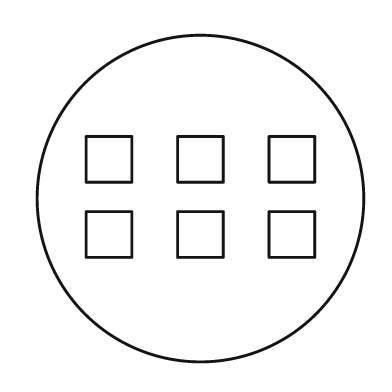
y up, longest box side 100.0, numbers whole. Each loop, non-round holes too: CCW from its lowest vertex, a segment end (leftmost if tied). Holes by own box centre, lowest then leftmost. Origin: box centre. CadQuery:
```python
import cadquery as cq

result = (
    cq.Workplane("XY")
    .moveTo(0.0, 0.0)
    .circle(50.0)
    .moveTo(-35.0, -18.0)
    .lineTo(-21.0, -18.0)
    .lineTo(-21.0, -4.0)
    .lineTo(-35.0, -4.0)
    .close()
    .moveTo(-7.0, -18.0)
    .lineTo(7.0, -18.0)
    .lineTo(7.0, -4.0)
    .lineTo(-7.0, -4.0)
    .close()
    .moveTo(21.0, -18.0)
    .lineTo(35.0, -18.0)
    .lineTo(35.0, -4.0)
    .lineTo(21.0, -4.0)
    .close()
    .moveTo(-35.0, 5.0)
    .lineTo(-21.0, 5.0)
    .lineTo(-21.0, 19.0)
    .lineTo(-35.0, 19.0)
    .close()
    .moveTo(-7.0, 5.0)
    .lineTo(7.0, 5.0)
    .lineTo(7.0, 19.0)
    .lineTo(-7.0, 19.0)
    .close()
    .moveTo(21.0, 5.0)
    .lineTo(35.0, 5.0)
    .lineTo(35.0, 19.0)
    .lineTo(21.0, 19.0)
    .close()
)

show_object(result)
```